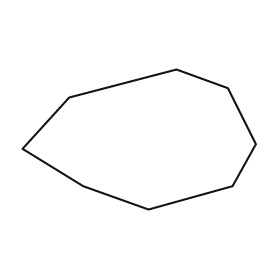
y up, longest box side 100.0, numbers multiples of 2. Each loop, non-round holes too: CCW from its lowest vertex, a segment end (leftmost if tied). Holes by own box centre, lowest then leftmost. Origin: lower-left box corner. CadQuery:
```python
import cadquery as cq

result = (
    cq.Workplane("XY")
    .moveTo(54.0, 0.0)
    .lineTo(90.0, 10.0)
    .lineTo(100.0, 28.0)
    .lineTo(88.0, 52.0)
    .lineTo(66.0, 60.0)
    .lineTo(20.0, 48.0)
    .lineTo(0.0, 26.0)
    .lineTo(26.0, 10.0)
    .close()
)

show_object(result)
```